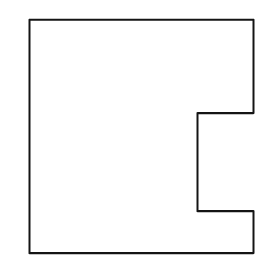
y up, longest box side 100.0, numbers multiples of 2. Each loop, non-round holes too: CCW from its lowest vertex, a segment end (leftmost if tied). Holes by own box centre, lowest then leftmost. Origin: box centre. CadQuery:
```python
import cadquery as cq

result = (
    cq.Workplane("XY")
    .moveTo(-48.0, -50.0)
    .lineTo(48.0, -50.0)
    .lineTo(48.0, -32.0)
    .lineTo(24.0, -32.0)
    .lineTo(24.0, 10.0)
    .lineTo(48.0, 10.0)
    .lineTo(48.0, 50.0)
    .lineTo(-48.0, 50.0)
    .close()
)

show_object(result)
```